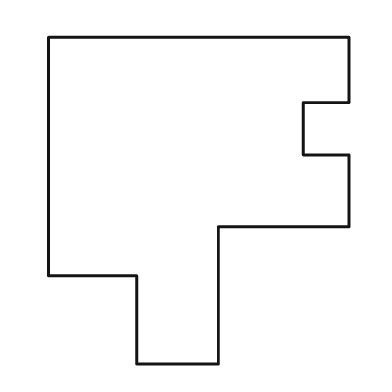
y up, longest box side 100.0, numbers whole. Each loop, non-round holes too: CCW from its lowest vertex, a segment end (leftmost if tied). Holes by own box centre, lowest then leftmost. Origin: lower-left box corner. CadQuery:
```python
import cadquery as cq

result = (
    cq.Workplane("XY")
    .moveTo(27.0, 0.0)
    .lineTo(52.0, 0.0)
    .lineTo(52.0, 42.0)
    .lineTo(92.0, 42.0)
    .lineTo(92.0, 64.0)
    .lineTo(78.0, 64.0)
    .lineTo(78.0, 80.0)
    .lineTo(92.0, 80.0)
    .lineTo(92.0, 100.0)
    .lineTo(0.0, 100.0)
    .lineTo(0.0, 27.0)
    .lineTo(27.0, 27.0)
    .close()
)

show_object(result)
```